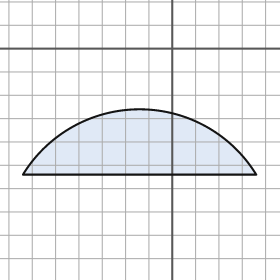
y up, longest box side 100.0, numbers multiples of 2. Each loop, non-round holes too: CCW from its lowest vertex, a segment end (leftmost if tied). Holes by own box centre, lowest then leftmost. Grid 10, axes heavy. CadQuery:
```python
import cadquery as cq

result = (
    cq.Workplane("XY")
    .moveTo(-64.0, -54.0)
    .lineTo(36.0, -54.0)
    .threePointArc((-14.0, -26.0), (-64.0, -54.0))
    .close()
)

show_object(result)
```